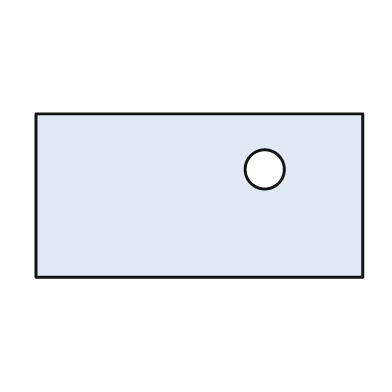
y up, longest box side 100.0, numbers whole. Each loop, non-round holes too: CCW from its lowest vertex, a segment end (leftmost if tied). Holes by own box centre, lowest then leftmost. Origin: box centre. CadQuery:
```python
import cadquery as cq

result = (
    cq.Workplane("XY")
    .moveTo(-50.0, -25.0)
    .lineTo(50.0, -25.0)
    .lineTo(50.0, 25.0)
    .lineTo(-50.0, 25.0)
    .close()
    .moveTo(20.0, 8.0)
    .circle(6.0)
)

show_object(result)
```